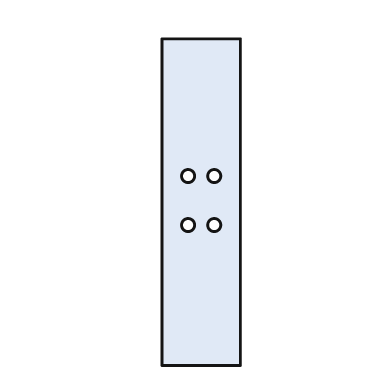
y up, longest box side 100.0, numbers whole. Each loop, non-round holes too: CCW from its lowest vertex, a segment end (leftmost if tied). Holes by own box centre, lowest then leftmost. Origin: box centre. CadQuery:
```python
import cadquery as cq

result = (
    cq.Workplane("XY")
    .moveTo(-12.0, -50.0)
    .lineTo(12.0, -50.0)
    .lineTo(12.0, 50.0)
    .lineTo(-12.0, 50.0)
    .close()
    .moveTo(-4.0, -7.0)
    .circle(2.0)
    .moveTo(4.0, -7.0)
    .circle(2.0)
    .moveTo(-4.0, 8.0)
    .circle(2.0)
    .moveTo(4.0, 8.0)
    .circle(2.0)
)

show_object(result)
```